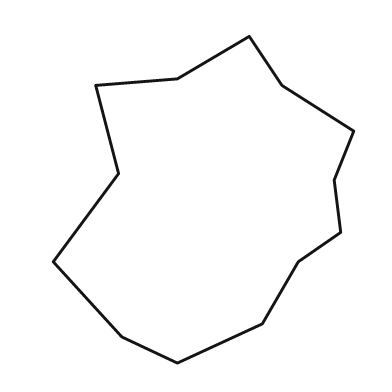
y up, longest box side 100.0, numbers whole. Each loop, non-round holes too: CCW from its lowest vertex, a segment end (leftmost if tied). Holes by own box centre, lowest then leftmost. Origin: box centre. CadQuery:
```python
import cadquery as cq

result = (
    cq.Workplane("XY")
    .moveTo(-8.0, -50.0)
    .lineTo(18.0, -38.0)
    .lineTo(29.0, -19.0)
    .lineTo(42.0, -10.0)
    .lineTo(40.0, 6.0)
    .lineTo(46.0, 21.0)
    .lineTo(24.0, 35.0)
    .lineTo(14.0, 50.0)
    .lineTo(-8.0, 37.0)
    .lineTo(-33.0, 35.0)
    .lineTo(-26.0, 8.0)
    .lineTo(-46.0, -19.0)
    .lineTo(-25.0, -42.0)
    .close()
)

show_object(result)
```